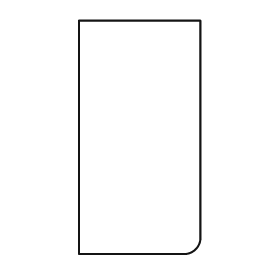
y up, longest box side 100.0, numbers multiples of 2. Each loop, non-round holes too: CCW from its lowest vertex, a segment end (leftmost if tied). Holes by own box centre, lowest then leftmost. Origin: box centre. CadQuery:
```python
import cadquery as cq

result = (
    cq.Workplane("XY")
    .moveTo(-26.0, -50.0)
    .lineTo(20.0, -50.0)
    .threePointArc((24.0, -48.0), (26.0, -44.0))
    .lineTo(26.0, 50.0)
    .lineTo(-26.0, 50.0)
    .close()
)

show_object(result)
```